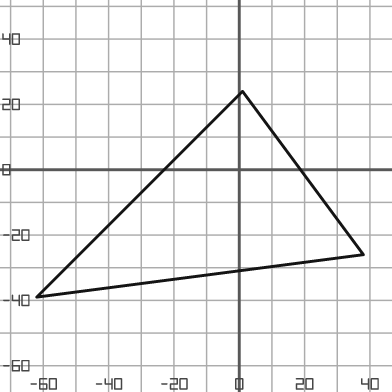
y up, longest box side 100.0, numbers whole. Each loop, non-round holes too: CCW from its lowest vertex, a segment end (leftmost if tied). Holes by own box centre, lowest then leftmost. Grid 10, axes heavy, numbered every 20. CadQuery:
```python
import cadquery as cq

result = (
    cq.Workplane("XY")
    .moveTo(-62.0, -39.0)
    .lineTo(38.0, -26.0)
    .lineTo(1.0, 24.0)
    .close()
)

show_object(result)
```